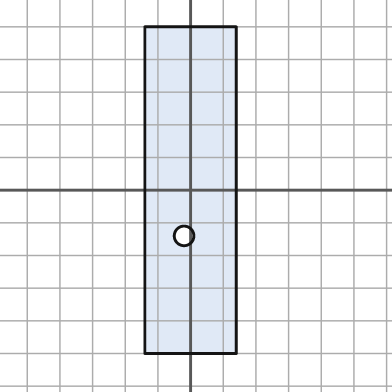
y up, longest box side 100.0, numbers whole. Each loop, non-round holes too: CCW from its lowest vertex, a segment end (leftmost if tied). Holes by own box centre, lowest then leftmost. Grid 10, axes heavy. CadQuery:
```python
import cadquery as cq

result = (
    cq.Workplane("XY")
    .moveTo(-14.0, -50.0)
    .lineTo(14.0, -50.0)
    .lineTo(14.0, 50.0)
    .lineTo(-14.0, 50.0)
    .close()
    .moveTo(-2.0, -14.0)
    .circle(3.0)
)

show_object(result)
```